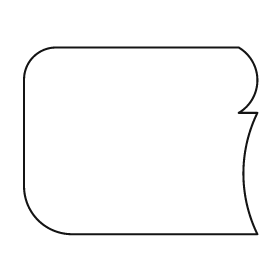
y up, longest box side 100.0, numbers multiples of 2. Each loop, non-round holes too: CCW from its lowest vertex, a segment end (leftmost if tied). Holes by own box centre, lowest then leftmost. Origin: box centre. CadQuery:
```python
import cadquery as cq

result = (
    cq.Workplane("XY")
    .moveTo(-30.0, -40.0)
    .lineTo(50.0, -40.0)
    .threePointArc((44.0, -14.0), (50.0, 12.0))
    .lineTo(42.0, 12.0)
    .threePointArc((50.0, 26.0), (42.0, 40.0))
    .lineTo(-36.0, 40.0)
    .threePointArc((-46.0, 36.0), (-50.0, 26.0))
    .lineTo(-50.0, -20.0)
    .threePointArc((-44.0, -34.0), (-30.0, -40.0))
    .close()
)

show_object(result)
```